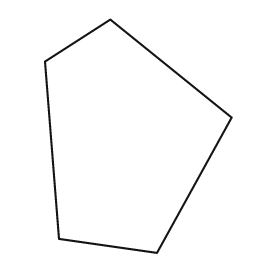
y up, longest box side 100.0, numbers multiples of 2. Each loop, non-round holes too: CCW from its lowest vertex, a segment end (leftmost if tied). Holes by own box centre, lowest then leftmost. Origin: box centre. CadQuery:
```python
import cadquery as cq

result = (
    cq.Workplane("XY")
    .moveTo(8.0, -50.0)
    .lineTo(40.0, 8.0)
    .lineTo(-12.0, 50.0)
    .lineTo(-40.0, 32.0)
    .lineTo(-34.0, -44.0)
    .close()
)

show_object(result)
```